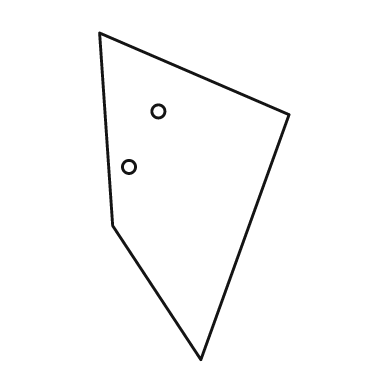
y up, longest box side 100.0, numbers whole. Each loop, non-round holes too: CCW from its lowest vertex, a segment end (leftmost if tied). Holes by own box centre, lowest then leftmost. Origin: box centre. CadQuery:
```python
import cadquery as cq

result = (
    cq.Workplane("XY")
    .moveTo(2.0, -50.0)
    .lineTo(29.0, 25.0)
    .lineTo(-29.0, 50.0)
    .lineTo(-25.0, -9.0)
    .close()
    .moveTo(-20.0, 9.0)
    .circle(2.0)
    .moveTo(-11.0, 26.0)
    .circle(2.0)
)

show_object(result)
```